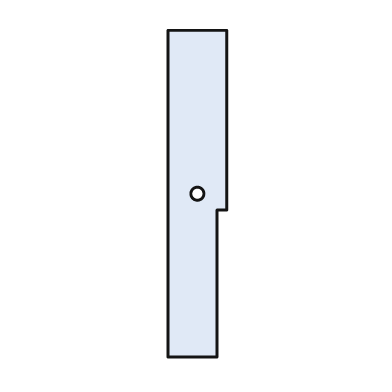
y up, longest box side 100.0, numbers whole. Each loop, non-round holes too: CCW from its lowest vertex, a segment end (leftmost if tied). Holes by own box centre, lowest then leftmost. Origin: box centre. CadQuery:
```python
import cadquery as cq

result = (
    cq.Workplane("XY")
    .moveTo(-9.0, -50.0)
    .lineTo(6.0, -50.0)
    .lineTo(6.0, -5.0)
    .lineTo(9.0, -5.0)
    .lineTo(9.0, 50.0)
    .lineTo(-9.0, 50.0)
    .close()
    .moveTo(0.0, 0.0)
    .circle(2.0)
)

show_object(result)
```